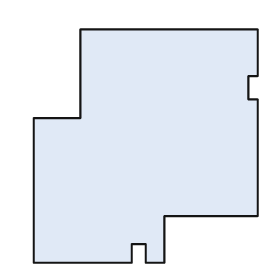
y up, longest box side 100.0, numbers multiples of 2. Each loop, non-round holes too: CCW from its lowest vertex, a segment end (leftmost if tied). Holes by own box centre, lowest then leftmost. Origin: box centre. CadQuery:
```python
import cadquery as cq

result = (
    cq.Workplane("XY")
    .moveTo(-48.0, -50.0)
    .lineTo(-6.0, -50.0)
    .lineTo(-6.0, -42.0)
    .lineTo(0.0, -42.0)
    .lineTo(0.0, -50.0)
    .lineTo(8.0, -50.0)
    .lineTo(8.0, -30.0)
    .lineTo(48.0, -30.0)
    .lineTo(48.0, 20.0)
    .lineTo(44.0, 20.0)
    .lineTo(44.0, 30.0)
    .lineTo(48.0, 30.0)
    .lineTo(48.0, 50.0)
    .lineTo(-28.0, 50.0)
    .lineTo(-28.0, 12.0)
    .lineTo(-48.0, 12.0)
    .close()
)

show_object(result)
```